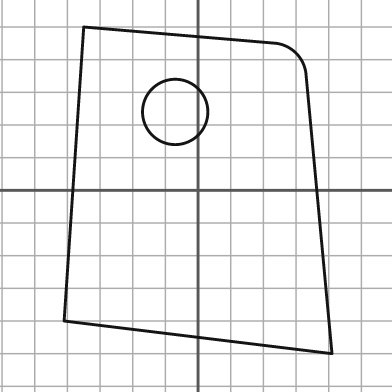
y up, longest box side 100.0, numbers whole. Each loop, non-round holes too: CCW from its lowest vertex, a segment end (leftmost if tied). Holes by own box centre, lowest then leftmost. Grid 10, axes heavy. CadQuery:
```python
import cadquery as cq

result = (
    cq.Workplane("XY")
    .moveTo(41.0, -50.0)
    .lineTo(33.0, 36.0)
    .threePointArc((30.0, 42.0), (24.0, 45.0))
    .lineTo(-35.0, 50.0)
    .lineTo(-41.0, -40.0)
    .close()
    .moveTo(-7.0, 24.0)
    .circle(10.0)
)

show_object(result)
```